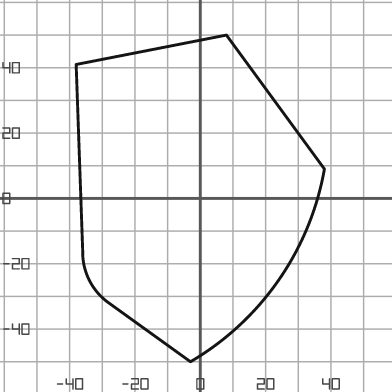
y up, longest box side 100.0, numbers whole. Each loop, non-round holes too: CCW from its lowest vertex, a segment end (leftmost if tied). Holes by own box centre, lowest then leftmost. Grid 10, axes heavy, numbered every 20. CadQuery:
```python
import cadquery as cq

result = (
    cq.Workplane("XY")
    .moveTo(-3.0, -50.0)
    .threePointArc((24.0, -25.0), (38.0, 9.0))
    .lineTo(8.0, 50.0)
    .lineTo(-38.0, 41.0)
    .lineTo(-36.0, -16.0)
    .threePointArc((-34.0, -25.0), (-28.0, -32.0))
    .close()
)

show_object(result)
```